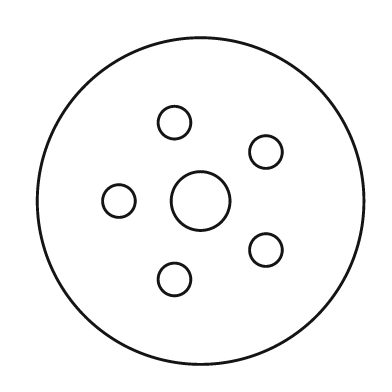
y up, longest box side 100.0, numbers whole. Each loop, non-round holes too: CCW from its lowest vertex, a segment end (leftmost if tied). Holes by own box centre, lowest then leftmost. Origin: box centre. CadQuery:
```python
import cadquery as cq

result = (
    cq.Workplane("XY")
    .moveTo(0.0, 0.0)
    .circle(50.0)
    .moveTo(-8.0, -24.0)
    .circle(5.0)
    .moveTo(20.0, -15.0)
    .circle(5.0)
    .moveTo(-25.0, 0.0)
    .circle(5.0)
    .moveTo(0.0, 0.0)
    .circle(9.0)
    .moveTo(20.0, 15.0)
    .circle(5.0)
    .moveTo(-8.0, 24.0)
    .circle(5.0)
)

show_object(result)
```